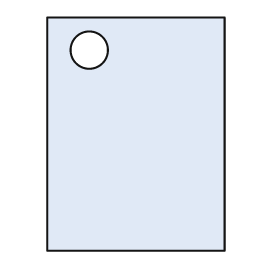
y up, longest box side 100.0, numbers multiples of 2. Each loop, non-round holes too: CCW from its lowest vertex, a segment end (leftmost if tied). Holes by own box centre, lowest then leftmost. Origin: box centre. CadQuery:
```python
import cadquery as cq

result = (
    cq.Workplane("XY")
    .moveTo(-38.0, -50.0)
    .lineTo(38.0, -50.0)
    .lineTo(38.0, 50.0)
    .lineTo(-38.0, 50.0)
    .close()
    .moveTo(-20.0, 36.0)
    .circle(8.0)
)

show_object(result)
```